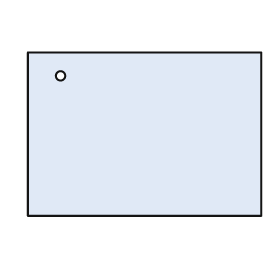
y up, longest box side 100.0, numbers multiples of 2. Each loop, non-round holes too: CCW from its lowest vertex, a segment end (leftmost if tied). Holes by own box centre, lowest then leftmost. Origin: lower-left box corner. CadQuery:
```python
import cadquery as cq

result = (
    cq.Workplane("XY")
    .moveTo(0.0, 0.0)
    .lineTo(100.0, 0.0)
    .lineTo(100.0, 70.0)
    .lineTo(0.0, 70.0)
    .close()
    .moveTo(14.0, 60.0)
    .circle(2.0)
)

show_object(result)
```